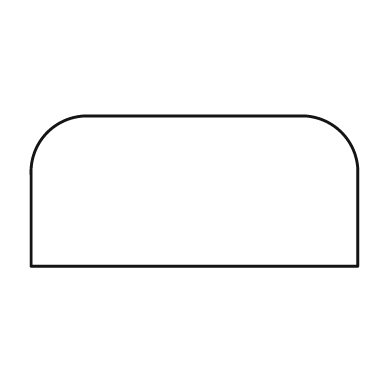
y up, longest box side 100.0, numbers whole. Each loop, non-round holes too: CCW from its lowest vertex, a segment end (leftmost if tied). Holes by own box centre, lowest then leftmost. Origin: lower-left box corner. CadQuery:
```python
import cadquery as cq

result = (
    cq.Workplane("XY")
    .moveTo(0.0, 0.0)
    .lineTo(100.0, 0.0)
    .lineTo(100.0, 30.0)
    .threePointArc((95.0, 41.0), (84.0, 46.0))
    .lineTo(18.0, 46.0)
    .threePointArc((5.0, 41.0), (0.0, 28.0))
    .close()
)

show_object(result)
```